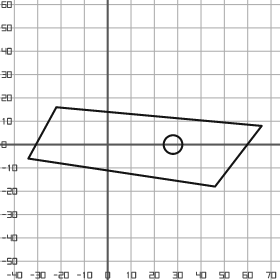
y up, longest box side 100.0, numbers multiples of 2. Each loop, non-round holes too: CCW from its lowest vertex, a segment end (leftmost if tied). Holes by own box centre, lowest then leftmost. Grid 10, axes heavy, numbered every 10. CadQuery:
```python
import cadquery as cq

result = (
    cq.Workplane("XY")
    .moveTo(46.0, -18.0)
    .lineTo(66.0, 8.0)
    .lineTo(-22.0, 16.0)
    .lineTo(-34.0, -6.0)
    .close()
    .moveTo(28.0, 0.0)
    .circle(4.0)
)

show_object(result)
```